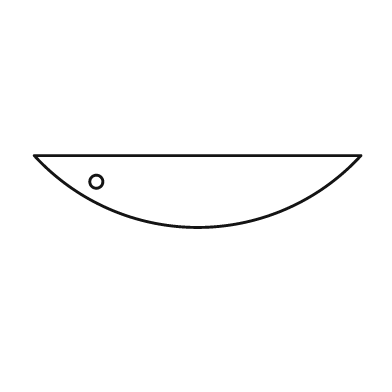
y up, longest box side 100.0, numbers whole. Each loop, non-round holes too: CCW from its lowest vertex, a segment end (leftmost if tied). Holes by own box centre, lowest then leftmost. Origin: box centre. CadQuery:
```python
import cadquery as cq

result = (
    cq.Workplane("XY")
    .moveTo(-50.0, 11.0)
    .threePointArc((0.0, -11.0), (50.0, 11.0))
    .close()
    .moveTo(-31.0, 3.0)
    .circle(2.0)
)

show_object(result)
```